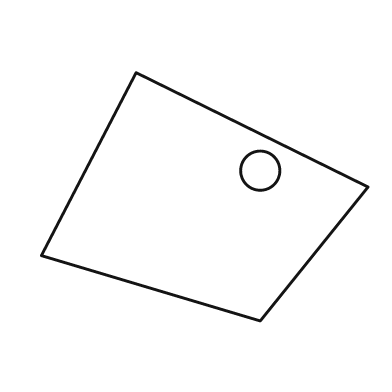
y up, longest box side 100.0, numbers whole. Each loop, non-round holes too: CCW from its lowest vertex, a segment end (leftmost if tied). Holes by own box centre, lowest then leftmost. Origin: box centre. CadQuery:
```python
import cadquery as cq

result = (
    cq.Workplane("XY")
    .moveTo(17.0, -38.0)
    .lineTo(50.0, 3.0)
    .lineTo(-21.0, 38.0)
    .lineTo(-50.0, -18.0)
    .close()
    .moveTo(17.0, 8.0)
    .circle(6.0)
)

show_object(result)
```